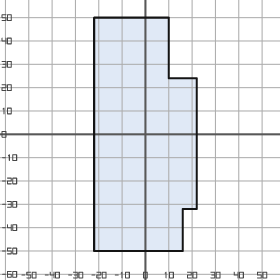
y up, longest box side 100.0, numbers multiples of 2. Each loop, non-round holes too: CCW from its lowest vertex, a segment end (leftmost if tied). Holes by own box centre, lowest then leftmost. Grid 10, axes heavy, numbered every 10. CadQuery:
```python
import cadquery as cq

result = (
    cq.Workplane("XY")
    .moveTo(-22.0, -50.0)
    .lineTo(16.0, -50.0)
    .lineTo(16.0, -32.0)
    .lineTo(22.0, -32.0)
    .lineTo(22.0, 24.0)
    .lineTo(10.0, 24.0)
    .lineTo(10.0, 50.0)
    .lineTo(-22.0, 50.0)
    .close()
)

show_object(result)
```